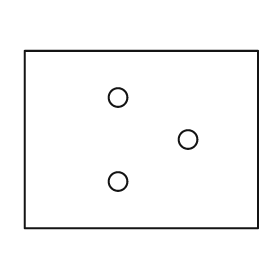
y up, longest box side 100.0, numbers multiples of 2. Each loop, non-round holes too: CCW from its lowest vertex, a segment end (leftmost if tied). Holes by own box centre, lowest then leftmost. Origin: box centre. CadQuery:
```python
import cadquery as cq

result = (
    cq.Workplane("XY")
    .moveTo(-50.0, -38.0)
    .lineTo(50.0, -38.0)
    .lineTo(50.0, 38.0)
    .lineTo(-50.0, 38.0)
    .close()
    .moveTo(-10.0, -18.0)
    .circle(4.0)
    .moveTo(20.0, 0.0)
    .circle(4.0)
    .moveTo(-10.0, 18.0)
    .circle(4.0)
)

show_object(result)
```